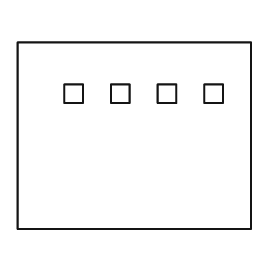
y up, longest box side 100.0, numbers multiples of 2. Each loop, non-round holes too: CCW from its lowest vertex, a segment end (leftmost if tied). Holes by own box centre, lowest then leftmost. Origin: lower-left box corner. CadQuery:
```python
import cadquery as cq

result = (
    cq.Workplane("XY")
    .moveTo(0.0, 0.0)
    .lineTo(100.0, 0.0)
    .lineTo(100.0, 80.0)
    .lineTo(0.0, 80.0)
    .close()
    .moveTo(20.0, 54.0)
    .lineTo(28.0, 54.0)
    .lineTo(28.0, 62.0)
    .lineTo(20.0, 62.0)
    .close()
    .moveTo(40.0, 54.0)
    .lineTo(48.0, 54.0)
    .lineTo(48.0, 62.0)
    .lineTo(40.0, 62.0)
    .close()
    .moveTo(60.0, 54.0)
    .lineTo(68.0, 54.0)
    .lineTo(68.0, 62.0)
    .lineTo(60.0, 62.0)
    .close()
    .moveTo(80.0, 54.0)
    .lineTo(88.0, 54.0)
    .lineTo(88.0, 62.0)
    .lineTo(80.0, 62.0)
    .close()
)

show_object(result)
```